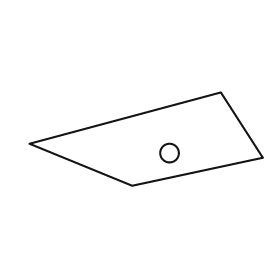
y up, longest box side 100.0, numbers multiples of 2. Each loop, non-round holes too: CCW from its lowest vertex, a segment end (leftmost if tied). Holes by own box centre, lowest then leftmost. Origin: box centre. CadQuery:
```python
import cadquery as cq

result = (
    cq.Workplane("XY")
    .moveTo(-6.0, -20.0)
    .lineTo(50.0, -8.0)
    .lineTo(32.0, 20.0)
    .lineTo(-50.0, -2.0)
    .close()
    .moveTo(10.0, -6.0)
    .circle(4.0)
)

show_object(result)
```